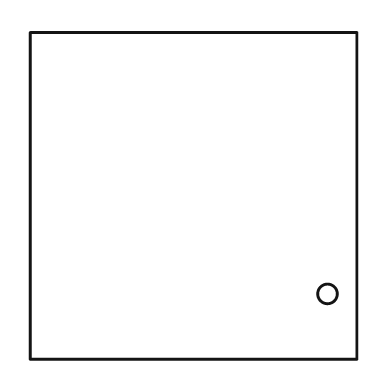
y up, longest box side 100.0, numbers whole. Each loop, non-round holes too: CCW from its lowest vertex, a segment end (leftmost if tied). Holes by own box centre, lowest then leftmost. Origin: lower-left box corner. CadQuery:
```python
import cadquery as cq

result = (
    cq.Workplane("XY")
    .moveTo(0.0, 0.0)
    .lineTo(100.0, 0.0)
    .lineTo(100.0, 100.0)
    .lineTo(0.0, 100.0)
    .close()
    .moveTo(91.0, 20.0)
    .circle(3.0)
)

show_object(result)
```